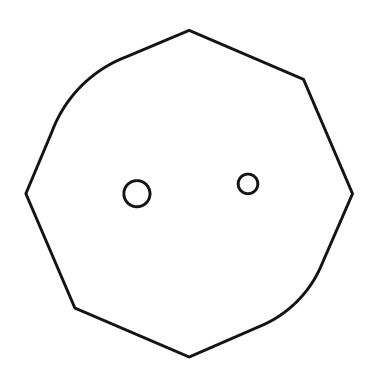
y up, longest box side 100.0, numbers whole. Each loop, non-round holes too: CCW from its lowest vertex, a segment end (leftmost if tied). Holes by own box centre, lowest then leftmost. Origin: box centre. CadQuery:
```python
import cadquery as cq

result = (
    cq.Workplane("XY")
    .moveTo(0.0, -50.0)
    .lineTo(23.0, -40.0)
    .threePointArc((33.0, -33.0), (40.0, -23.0))
    .lineTo(50.0, 0.0)
    .lineTo(35.0, 35.0)
    .lineTo(0.0, 50.0)
    .lineTo(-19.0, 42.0)
    .threePointArc((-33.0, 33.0), (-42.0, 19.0))
    .lineTo(-50.0, 0.0)
    .lineTo(-35.0, -35.0)
    .close()
    .moveTo(-16.0, 0.0)
    .circle(4.0)
    .moveTo(18.0, 3.0)
    .circle(3.0)
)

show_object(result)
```